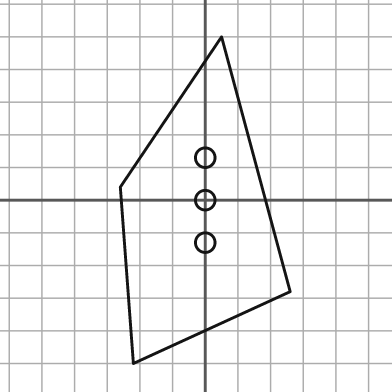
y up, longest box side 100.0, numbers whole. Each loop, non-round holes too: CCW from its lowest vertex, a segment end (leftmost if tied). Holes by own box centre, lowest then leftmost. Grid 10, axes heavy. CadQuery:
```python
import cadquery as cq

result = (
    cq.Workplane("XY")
    .moveTo(-22.0, -50.0)
    .lineTo(26.0, -28.0)
    .lineTo(5.0, 50.0)
    .lineTo(-26.0, 4.0)
    .close()
    .moveTo(0.0, -13.0)
    .circle(3.0)
    .moveTo(0.0, 0.0)
    .circle(3.0)
    .moveTo(0.0, 13.0)
    .circle(3.0)
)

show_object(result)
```